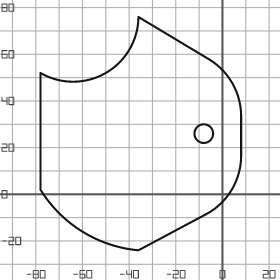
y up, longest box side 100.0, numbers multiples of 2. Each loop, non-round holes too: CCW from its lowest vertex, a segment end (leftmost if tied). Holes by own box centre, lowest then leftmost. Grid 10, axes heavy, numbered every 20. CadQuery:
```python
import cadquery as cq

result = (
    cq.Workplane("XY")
    .moveTo(-36.0, -24.0)
    .lineTo(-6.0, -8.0)
    .threePointArc((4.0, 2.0), (8.0, 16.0))
    .lineTo(8.0, 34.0)
    .threePointArc((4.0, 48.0), (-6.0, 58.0))
    .lineTo(-36.0, 76.0)
    .threePointArc((-50.0, 52.0), (-78.0, 52.0))
    .lineTo(-78.0, 2.0)
    .threePointArc((-60.0, -16.0), (-36.0, -24.0))
    .close()
    .moveTo(-8.0, 26.0)
    .circle(4.0)
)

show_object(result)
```